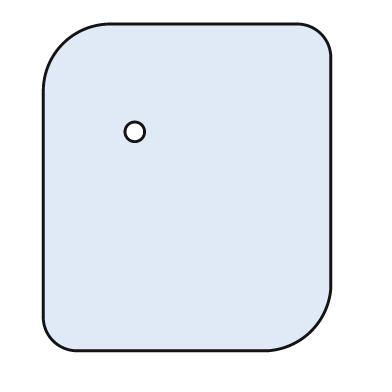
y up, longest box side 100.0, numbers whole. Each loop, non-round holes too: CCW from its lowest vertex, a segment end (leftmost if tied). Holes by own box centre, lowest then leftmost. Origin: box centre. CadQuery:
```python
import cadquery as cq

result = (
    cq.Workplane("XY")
    .moveTo(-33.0, -50.0)
    .lineTo(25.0, -50.0)
    .threePointArc((38.0, -44.0), (44.0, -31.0))
    .lineTo(44.0, 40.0)
    .threePointArc((41.0, 47.0), (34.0, 50.0))
    .lineTo(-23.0, 50.0)
    .threePointArc((-38.0, 44.0), (-44.0, 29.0))
    .lineTo(-44.0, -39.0)
    .threePointArc((-41.0, -47.0), (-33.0, -50.0))
    .close()
    .moveTo(-16.0, 17.0)
    .circle(3.0)
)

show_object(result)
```